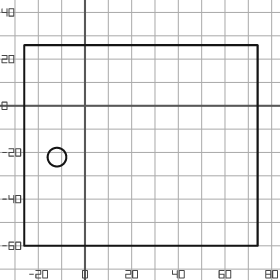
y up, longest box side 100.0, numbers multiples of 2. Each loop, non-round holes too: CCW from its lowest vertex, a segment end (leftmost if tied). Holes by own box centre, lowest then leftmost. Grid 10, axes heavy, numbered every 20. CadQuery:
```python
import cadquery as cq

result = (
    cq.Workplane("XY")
    .moveTo(-26.0, -60.0)
    .lineTo(74.0, -60.0)
    .lineTo(74.0, 26.0)
    .lineTo(-26.0, 26.0)
    .close()
    .moveTo(-12.0, -22.0)
    .circle(4.0)
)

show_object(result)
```